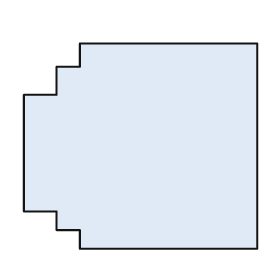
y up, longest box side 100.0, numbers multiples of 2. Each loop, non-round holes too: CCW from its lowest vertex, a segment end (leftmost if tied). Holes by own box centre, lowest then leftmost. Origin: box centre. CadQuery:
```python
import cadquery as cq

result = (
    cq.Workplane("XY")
    .moveTo(-26.0, -44.0)
    .lineTo(50.0, -44.0)
    .lineTo(50.0, 44.0)
    .lineTo(-26.0, 44.0)
    .lineTo(-26.0, 34.0)
    .lineTo(-36.0, 34.0)
    .lineTo(-36.0, 22.0)
    .lineTo(-50.0, 22.0)
    .lineTo(-50.0, -28.0)
    .lineTo(-36.0, -28.0)
    .lineTo(-36.0, -36.0)
    .lineTo(-26.0, -36.0)
    .close()
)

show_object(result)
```